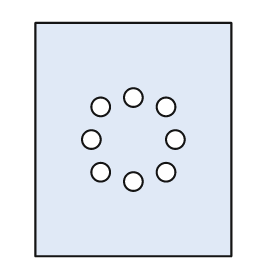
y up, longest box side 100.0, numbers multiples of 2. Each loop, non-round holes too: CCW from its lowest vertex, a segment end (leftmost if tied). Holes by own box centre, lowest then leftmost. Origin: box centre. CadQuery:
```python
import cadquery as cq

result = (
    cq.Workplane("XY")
    .moveTo(-42.0, -50.0)
    .lineTo(42.0, -50.0)
    .lineTo(42.0, 50.0)
    .lineTo(-42.0, 50.0)
    .close()
    .moveTo(0.0, -18.0)
    .circle(4.0)
    .moveTo(-14.0, -14.0)
    .circle(4.0)
    .moveTo(14.0, -14.0)
    .circle(4.0)
    .moveTo(-18.0, 0.0)
    .circle(4.0)
    .moveTo(18.0, 0.0)
    .circle(4.0)
    .moveTo(-14.0, 14.0)
    .circle(4.0)
    .moveTo(14.0, 14.0)
    .circle(4.0)
    .moveTo(0.0, 18.0)
    .circle(4.0)
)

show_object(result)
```